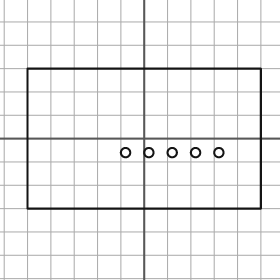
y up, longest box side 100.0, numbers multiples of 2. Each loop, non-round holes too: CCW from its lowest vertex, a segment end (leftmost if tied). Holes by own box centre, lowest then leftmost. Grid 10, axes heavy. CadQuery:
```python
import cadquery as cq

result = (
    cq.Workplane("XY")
    .moveTo(-50.0, -30.0)
    .lineTo(50.0, -30.0)
    .lineTo(50.0, 30.0)
    .lineTo(-50.0, 30.0)
    .close()
    .moveTo(-8.0, -6.0)
    .circle(2.0)
    .moveTo(2.0, -6.0)
    .circle(2.0)
    .moveTo(12.0, -6.0)
    .circle(2.0)
    .moveTo(22.0, -6.0)
    .circle(2.0)
    .moveTo(32.0, -6.0)
    .circle(2.0)
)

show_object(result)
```